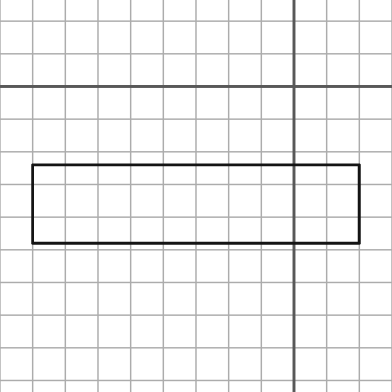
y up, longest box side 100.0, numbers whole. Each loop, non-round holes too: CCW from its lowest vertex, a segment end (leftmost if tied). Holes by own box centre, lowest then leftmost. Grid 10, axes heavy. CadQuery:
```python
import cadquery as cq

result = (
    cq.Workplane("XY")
    .moveTo(-80.0, -48.0)
    .lineTo(20.0, -48.0)
    .lineTo(20.0, -24.0)
    .lineTo(-80.0, -24.0)
    .close()
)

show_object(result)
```